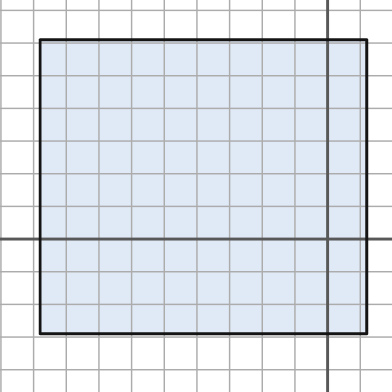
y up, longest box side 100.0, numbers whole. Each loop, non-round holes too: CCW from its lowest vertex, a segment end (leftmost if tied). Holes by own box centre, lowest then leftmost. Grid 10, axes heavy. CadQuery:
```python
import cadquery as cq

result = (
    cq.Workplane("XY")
    .moveTo(-88.0, -29.0)
    .lineTo(12.0, -29.0)
    .lineTo(12.0, 61.0)
    .lineTo(-88.0, 61.0)
    .close()
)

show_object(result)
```